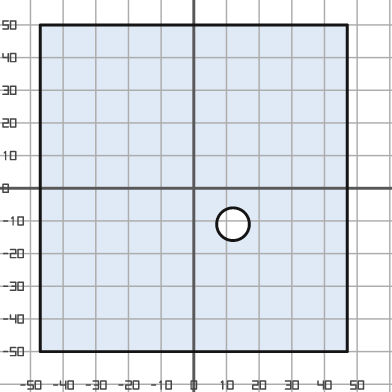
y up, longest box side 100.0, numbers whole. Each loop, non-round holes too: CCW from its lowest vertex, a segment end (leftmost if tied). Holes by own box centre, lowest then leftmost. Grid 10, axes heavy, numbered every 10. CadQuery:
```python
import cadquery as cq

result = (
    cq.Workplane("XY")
    .moveTo(-47.0, -50.0)
    .lineTo(47.0, -50.0)
    .lineTo(47.0, 50.0)
    .lineTo(-47.0, 50.0)
    .close()
    .moveTo(12.0, -11.0)
    .circle(5.0)
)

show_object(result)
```